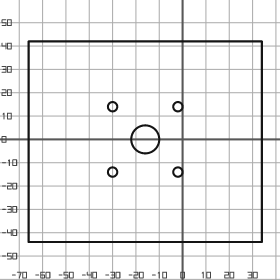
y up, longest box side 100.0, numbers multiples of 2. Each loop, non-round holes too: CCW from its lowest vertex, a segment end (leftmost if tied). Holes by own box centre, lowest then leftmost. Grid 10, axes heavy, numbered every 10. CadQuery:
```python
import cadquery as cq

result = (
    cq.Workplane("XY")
    .moveTo(-66.0, -44.0)
    .lineTo(34.0, -44.0)
    .lineTo(34.0, 42.0)
    .lineTo(-66.0, 42.0)
    .close()
    .moveTo(-30.0, -14.0)
    .circle(2.0)
    .moveTo(-2.0, -14.0)
    .circle(2.0)
    .moveTo(-16.0, 0.0)
    .circle(6.0)
    .moveTo(-30.0, 14.0)
    .circle(2.0)
    .moveTo(-2.0, 14.0)
    .circle(2.0)
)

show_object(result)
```